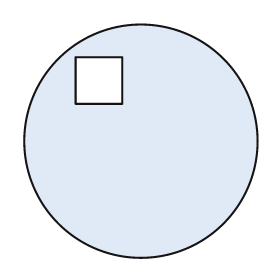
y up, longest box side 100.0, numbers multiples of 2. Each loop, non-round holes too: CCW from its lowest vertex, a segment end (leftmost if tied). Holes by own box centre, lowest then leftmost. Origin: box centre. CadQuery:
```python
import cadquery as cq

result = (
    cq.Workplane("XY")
    .moveTo(0.0, 0.0)
    .circle(50.0)
    .moveTo(-28.0, 16.0)
    .lineTo(-8.0, 16.0)
    .lineTo(-8.0, 36.0)
    .lineTo(-28.0, 36.0)
    .close()
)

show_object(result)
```